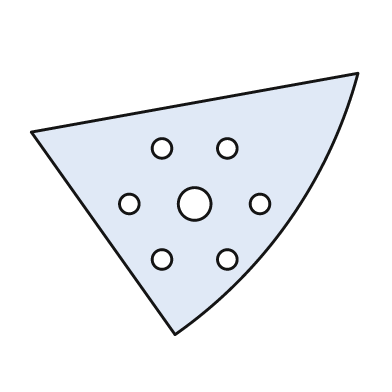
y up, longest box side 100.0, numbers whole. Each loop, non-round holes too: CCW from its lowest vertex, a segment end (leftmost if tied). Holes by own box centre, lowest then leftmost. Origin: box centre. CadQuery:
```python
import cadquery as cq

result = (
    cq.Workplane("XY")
    .moveTo(-6.0, -40.0)
    .threePointArc((29.0, -5.0), (50.0, 40.0))
    .lineTo(-50.0, 22.0)
    .close()
    .moveTo(-10.0, -17.0)
    .circle(3.0)
    .moveTo(10.0, -17.0)
    .circle(3.0)
    .moveTo(-20.0, 0.0)
    .circle(3.0)
    .moveTo(0.0, 0.0)
    .circle(5.0)
    .moveTo(20.0, 0.0)
    .circle(3.0)
    .moveTo(-10.0, 17.0)
    .circle(3.0)
    .moveTo(10.0, 17.0)
    .circle(3.0)
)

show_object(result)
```